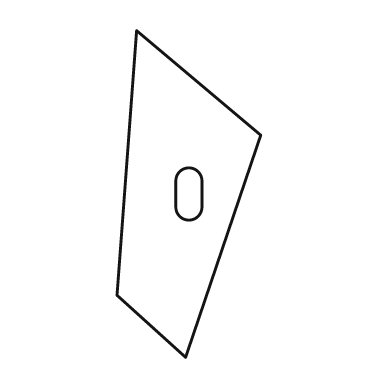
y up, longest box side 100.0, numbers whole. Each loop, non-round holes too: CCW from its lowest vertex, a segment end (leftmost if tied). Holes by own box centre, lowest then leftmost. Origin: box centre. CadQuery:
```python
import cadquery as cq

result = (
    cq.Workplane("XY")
    .moveTo(-1.0, -50.0)
    .lineTo(22.0, 18.0)
    .lineTo(-16.0, 50.0)
    .lineTo(-22.0, -31.0)
    .close()
    .moveTo(-4.0, -4.0)
    .threePointArc((0.0, -8.0), (4.0, -4.0))
    .lineTo(4.0, 4.0)
    .threePointArc((0.0, 8.0), (-4.0, 4.0))
    .close()
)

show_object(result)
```